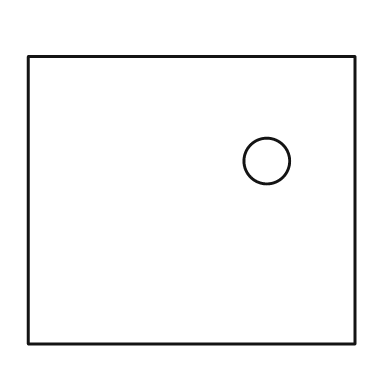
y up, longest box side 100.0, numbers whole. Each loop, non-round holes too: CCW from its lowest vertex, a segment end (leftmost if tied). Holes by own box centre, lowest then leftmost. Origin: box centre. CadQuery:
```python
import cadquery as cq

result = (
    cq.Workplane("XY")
    .moveTo(-50.0, -44.0)
    .lineTo(50.0, -44.0)
    .lineTo(50.0, 44.0)
    .lineTo(-50.0, 44.0)
    .close()
    .moveTo(23.0, 12.0)
    .circle(7.0)
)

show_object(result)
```